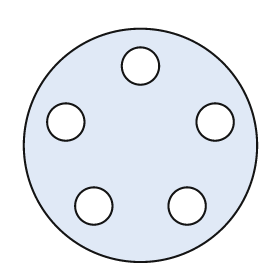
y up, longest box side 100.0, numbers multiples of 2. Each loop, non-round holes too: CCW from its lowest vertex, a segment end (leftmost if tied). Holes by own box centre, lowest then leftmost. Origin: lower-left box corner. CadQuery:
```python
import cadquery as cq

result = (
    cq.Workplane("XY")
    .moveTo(50.0, 50.0)
    .circle(50.0)
    .moveTo(30.0, 24.0)
    .circle(8.0)
    .moveTo(70.0, 24.0)
    .circle(8.0)
    .moveTo(18.0, 60.0)
    .circle(8.0)
    .moveTo(82.0, 60.0)
    .circle(8.0)
    .moveTo(50.0, 84.0)
    .circle(8.0)
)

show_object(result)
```